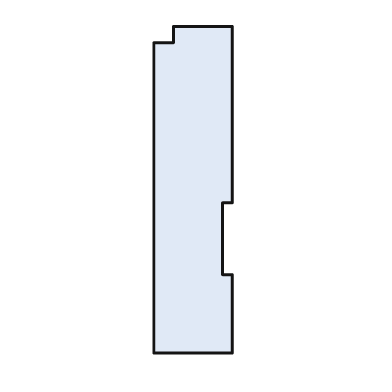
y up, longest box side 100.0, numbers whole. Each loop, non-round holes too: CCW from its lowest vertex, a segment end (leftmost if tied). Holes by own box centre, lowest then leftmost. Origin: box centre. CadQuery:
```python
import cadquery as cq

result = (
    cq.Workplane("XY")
    .moveTo(-12.0, -50.0)
    .lineTo(12.0, -50.0)
    .lineTo(12.0, -26.0)
    .lineTo(9.0, -26.0)
    .lineTo(9.0, -4.0)
    .lineTo(12.0, -4.0)
    .lineTo(12.0, 50.0)
    .lineTo(-6.0, 50.0)
    .lineTo(-6.0, 45.0)
    .lineTo(-12.0, 45.0)
    .close()
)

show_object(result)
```